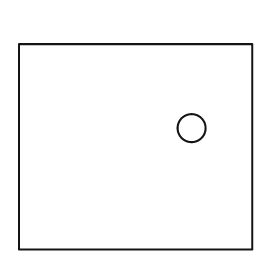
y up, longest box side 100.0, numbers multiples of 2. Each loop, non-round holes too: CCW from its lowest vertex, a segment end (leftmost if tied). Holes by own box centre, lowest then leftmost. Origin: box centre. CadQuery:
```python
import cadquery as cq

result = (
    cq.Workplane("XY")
    .moveTo(-50.0, -44.0)
    .lineTo(50.0, -44.0)
    .lineTo(50.0, 44.0)
    .lineTo(-50.0, 44.0)
    .close()
    .moveTo(24.0, 8.0)
    .circle(6.0)
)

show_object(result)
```